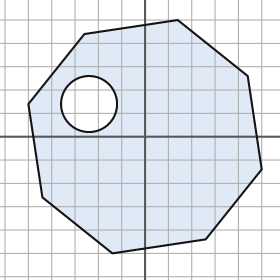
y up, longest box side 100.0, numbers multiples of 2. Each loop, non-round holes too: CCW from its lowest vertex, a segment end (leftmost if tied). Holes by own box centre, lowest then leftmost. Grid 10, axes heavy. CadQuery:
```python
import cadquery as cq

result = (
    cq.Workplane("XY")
    .moveTo(-14.0, -50.0)
    .lineTo(26.0, -44.0)
    .lineTo(50.0, -14.0)
    .lineTo(44.0, 26.0)
    .lineTo(14.0, 50.0)
    .lineTo(-26.0, 44.0)
    .lineTo(-50.0, 14.0)
    .lineTo(-44.0, -26.0)
    .close()
    .moveTo(-24.0, 14.0)
    .circle(12.0)
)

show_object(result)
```